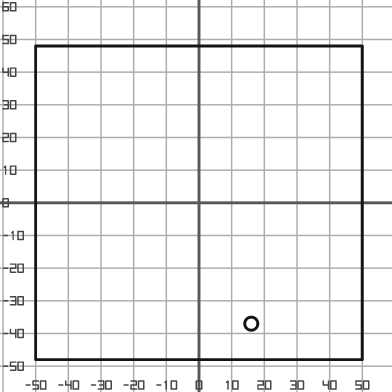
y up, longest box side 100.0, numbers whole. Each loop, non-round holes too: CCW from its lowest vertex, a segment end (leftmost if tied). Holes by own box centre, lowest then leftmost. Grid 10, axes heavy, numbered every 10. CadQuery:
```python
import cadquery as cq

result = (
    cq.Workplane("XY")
    .moveTo(-50.0, -48.0)
    .lineTo(50.0, -48.0)
    .lineTo(50.0, 48.0)
    .lineTo(-50.0, 48.0)
    .close()
    .moveTo(16.0, -37.0)
    .circle(2.0)
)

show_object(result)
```